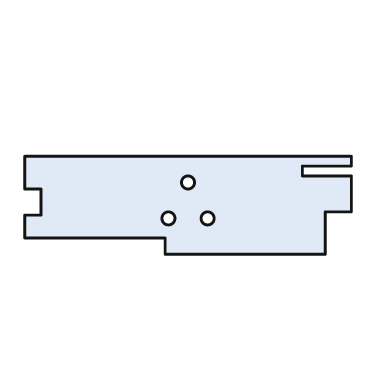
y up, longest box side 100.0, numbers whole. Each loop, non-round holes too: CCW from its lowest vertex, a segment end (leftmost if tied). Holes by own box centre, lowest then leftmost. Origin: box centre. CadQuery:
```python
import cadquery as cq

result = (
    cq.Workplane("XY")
    .moveTo(-7.0, -15.0)
    .lineTo(42.0, -15.0)
    .lineTo(42.0, -2.0)
    .lineTo(50.0, -2.0)
    .lineTo(50.0, 9.0)
    .lineTo(35.0, 9.0)
    .lineTo(35.0, 12.0)
    .lineTo(50.0, 12.0)
    .lineTo(50.0, 15.0)
    .lineTo(-50.0, 15.0)
    .lineTo(-50.0, 5.0)
    .lineTo(-45.0, 5.0)
    .lineTo(-45.0, -3.0)
    .lineTo(-50.0, -3.0)
    .lineTo(-50.0, -10.0)
    .lineTo(-7.0, -10.0)
    .close()
    .moveTo(-6.0, -4.0)
    .circle(2.0)
    .moveTo(6.0, -4.0)
    .circle(2.0)
    .moveTo(0.0, 7.0)
    .circle(2.0)
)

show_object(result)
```